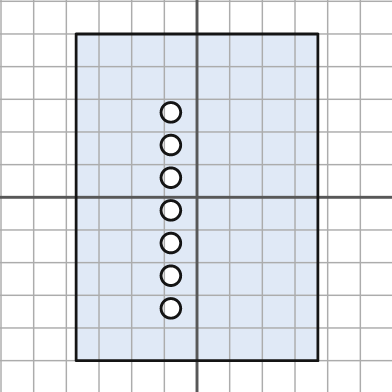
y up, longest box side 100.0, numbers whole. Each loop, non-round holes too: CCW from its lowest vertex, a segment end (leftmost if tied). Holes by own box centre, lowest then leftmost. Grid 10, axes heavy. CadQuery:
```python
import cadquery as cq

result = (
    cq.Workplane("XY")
    .moveTo(-37.0, -50.0)
    .lineTo(37.0, -50.0)
    .lineTo(37.0, 50.0)
    .lineTo(-37.0, 50.0)
    .close()
    .moveTo(-8.0, -34.0)
    .circle(3.0)
    .moveTo(-8.0, -24.0)
    .circle(3.0)
    .moveTo(-8.0, -14.0)
    .circle(3.0)
    .moveTo(-8.0, -4.0)
    .circle(3.0)
    .moveTo(-8.0, 6.0)
    .circle(3.0)
    .moveTo(-8.0, 16.0)
    .circle(3.0)
    .moveTo(-8.0, 26.0)
    .circle(3.0)
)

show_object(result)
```